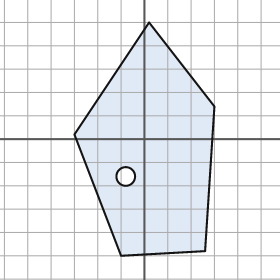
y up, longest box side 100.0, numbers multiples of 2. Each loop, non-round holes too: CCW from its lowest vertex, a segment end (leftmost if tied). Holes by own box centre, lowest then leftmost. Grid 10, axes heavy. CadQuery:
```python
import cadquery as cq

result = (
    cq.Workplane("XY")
    .moveTo(-10.0, -50.0)
    .lineTo(26.0, -48.0)
    .lineTo(30.0, 14.0)
    .lineTo(2.0, 50.0)
    .lineTo(-30.0, 2.0)
    .close()
    .moveTo(-8.0, -16.0)
    .circle(4.0)
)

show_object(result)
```